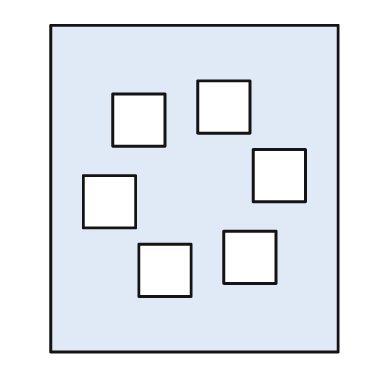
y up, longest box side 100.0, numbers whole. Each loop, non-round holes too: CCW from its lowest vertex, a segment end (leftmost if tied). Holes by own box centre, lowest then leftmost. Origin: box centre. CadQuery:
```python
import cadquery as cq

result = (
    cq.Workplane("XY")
    .moveTo(-44.0, -50.0)
    .lineTo(44.0, -50.0)
    .lineTo(44.0, 50.0)
    .lineTo(-44.0, 50.0)
    .close()
    .moveTo(-17.0, -33.0)
    .lineTo(-1.0, -33.0)
    .lineTo(-1.0, -17.0)
    .lineTo(-17.0, -17.0)
    .close()
    .moveTo(9.0, -29.0)
    .lineTo(25.0, -29.0)
    .lineTo(25.0, -13.0)
    .lineTo(9.0, -13.0)
    .close()
    .moveTo(-34.0, -12.0)
    .lineTo(-18.0, -12.0)
    .lineTo(-18.0, 4.0)
    .lineTo(-34.0, 4.0)
    .close()
    .moveTo(18.0, -4.0)
    .lineTo(34.0, -4.0)
    .lineTo(34.0, 12.0)
    .lineTo(18.0, 12.0)
    .close()
    .moveTo(-25.0, 13.0)
    .lineTo(-9.0, 13.0)
    .lineTo(-9.0, 29.0)
    .lineTo(-25.0, 29.0)
    .close()
    .moveTo(1.0, 17.0)
    .lineTo(17.0, 17.0)
    .lineTo(17.0, 33.0)
    .lineTo(1.0, 33.0)
    .close()
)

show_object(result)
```